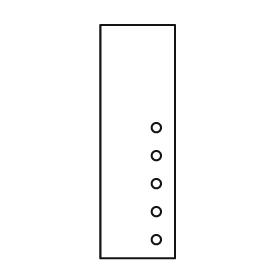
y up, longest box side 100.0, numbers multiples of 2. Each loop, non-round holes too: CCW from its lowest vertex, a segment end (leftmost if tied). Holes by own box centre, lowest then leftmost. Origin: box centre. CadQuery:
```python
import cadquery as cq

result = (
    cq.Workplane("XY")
    .moveTo(-16.0, -50.0)
    .lineTo(16.0, -50.0)
    .lineTo(16.0, 50.0)
    .lineTo(-16.0, 50.0)
    .close()
    .moveTo(8.0, -42.0)
    .circle(2.0)
    .moveTo(8.0, -30.0)
    .circle(2.0)
    .moveTo(8.0, -18.0)
    .circle(2.0)
    .moveTo(8.0, -6.0)
    .circle(2.0)
    .moveTo(8.0, 6.0)
    .circle(2.0)
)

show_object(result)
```